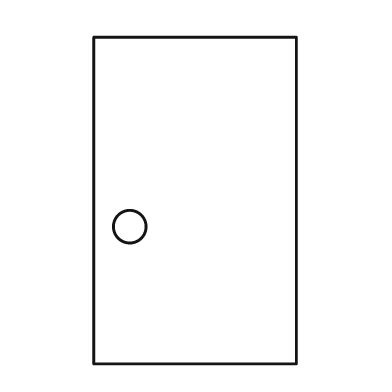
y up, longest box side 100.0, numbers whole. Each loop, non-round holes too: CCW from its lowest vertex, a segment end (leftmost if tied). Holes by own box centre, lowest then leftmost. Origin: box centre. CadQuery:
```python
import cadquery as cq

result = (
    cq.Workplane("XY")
    .moveTo(-31.0, -50.0)
    .lineTo(31.0, -50.0)
    .lineTo(31.0, 50.0)
    .lineTo(-31.0, 50.0)
    .close()
    .moveTo(-20.0, -8.0)
    .circle(5.0)
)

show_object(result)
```